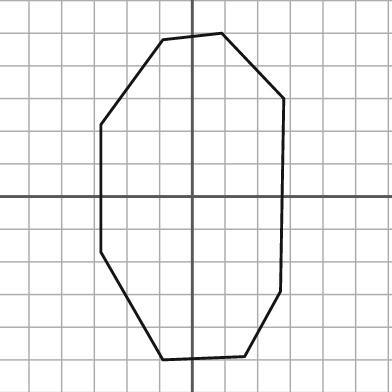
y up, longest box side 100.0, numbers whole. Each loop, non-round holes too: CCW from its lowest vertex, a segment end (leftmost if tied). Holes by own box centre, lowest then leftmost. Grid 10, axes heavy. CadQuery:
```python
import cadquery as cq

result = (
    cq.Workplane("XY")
    .moveTo(-9.0, -50.0)
    .lineTo(16.0, -49.0)
    .lineTo(27.0, -29.0)
    .lineTo(28.0, 30.0)
    .lineTo(9.0, 50.0)
    .lineTo(-9.0, 48.0)
    .lineTo(-28.0, 22.0)
    .lineTo(-28.0, -17.0)
    .close()
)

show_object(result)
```